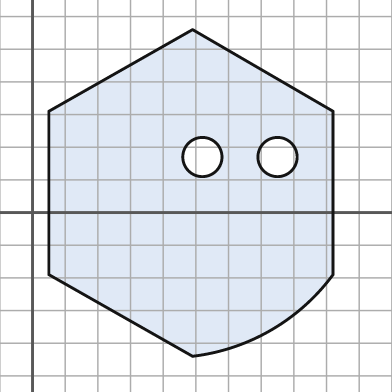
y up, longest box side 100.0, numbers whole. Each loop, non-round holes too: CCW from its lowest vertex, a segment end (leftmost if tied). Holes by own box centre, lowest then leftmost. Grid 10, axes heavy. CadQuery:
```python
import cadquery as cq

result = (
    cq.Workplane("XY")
    .moveTo(49.0, -44.0)
    .threePointArc((73.0, -36.0), (92.0, -19.0))
    .lineTo(92.0, 31.0)
    .lineTo(49.0, 56.0)
    .lineTo(5.0, 31.0)
    .lineTo(5.0, -19.0)
    .close()
    .moveTo(52.0, 17.0)
    .circle(6.0)
    .moveTo(75.0, 17.0)
    .circle(6.0)
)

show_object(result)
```